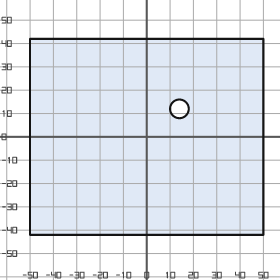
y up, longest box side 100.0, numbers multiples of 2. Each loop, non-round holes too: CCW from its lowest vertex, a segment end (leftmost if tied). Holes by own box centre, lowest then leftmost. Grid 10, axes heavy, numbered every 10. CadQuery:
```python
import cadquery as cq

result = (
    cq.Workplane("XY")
    .moveTo(-50.0, -42.0)
    .lineTo(50.0, -42.0)
    .lineTo(50.0, 42.0)
    .lineTo(-50.0, 42.0)
    .close()
    .moveTo(14.0, 12.0)
    .circle(4.0)
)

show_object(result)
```